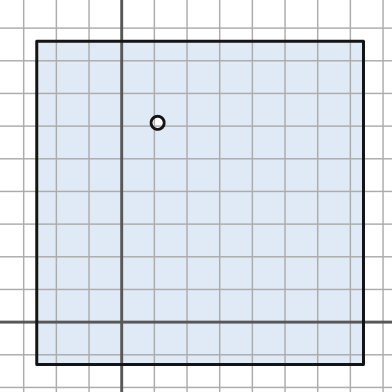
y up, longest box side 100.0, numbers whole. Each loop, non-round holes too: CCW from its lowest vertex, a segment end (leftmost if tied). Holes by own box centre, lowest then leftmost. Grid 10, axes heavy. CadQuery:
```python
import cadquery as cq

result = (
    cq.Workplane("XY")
    .moveTo(-26.0, -13.0)
    .lineTo(74.0, -13.0)
    .lineTo(74.0, 86.0)
    .lineTo(-26.0, 86.0)
    .close()
    .moveTo(11.0, 61.0)
    .circle(2.0)
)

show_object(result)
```